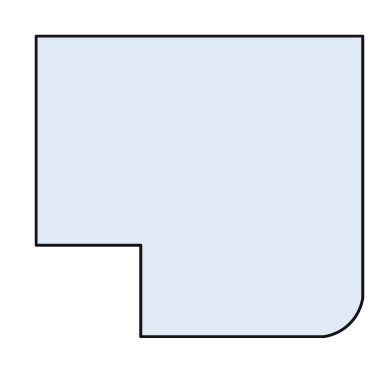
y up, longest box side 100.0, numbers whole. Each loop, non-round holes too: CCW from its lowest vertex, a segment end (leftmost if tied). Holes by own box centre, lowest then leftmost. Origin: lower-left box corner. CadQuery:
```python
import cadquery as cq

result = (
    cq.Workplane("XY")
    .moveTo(32.0, 0.0)
    .lineTo(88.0, 0.0)
    .threePointArc((96.0, 4.0), (100.0, 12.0))
    .lineTo(100.0, 92.0)
    .lineTo(0.0, 92.0)
    .lineTo(0.0, 28.0)
    .lineTo(32.0, 28.0)
    .close()
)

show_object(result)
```